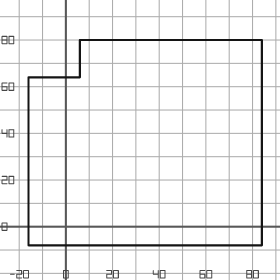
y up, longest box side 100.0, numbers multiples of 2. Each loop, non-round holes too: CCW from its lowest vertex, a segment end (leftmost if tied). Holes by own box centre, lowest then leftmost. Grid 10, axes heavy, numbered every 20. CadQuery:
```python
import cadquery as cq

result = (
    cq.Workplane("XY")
    .moveTo(-16.0, -8.0)
    .lineTo(84.0, -8.0)
    .lineTo(84.0, 80.0)
    .lineTo(6.0, 80.0)
    .lineTo(6.0, 64.0)
    .lineTo(-16.0, 64.0)
    .close()
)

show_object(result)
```